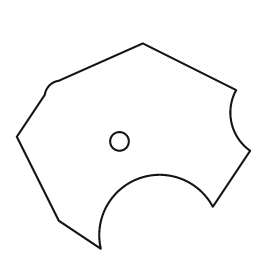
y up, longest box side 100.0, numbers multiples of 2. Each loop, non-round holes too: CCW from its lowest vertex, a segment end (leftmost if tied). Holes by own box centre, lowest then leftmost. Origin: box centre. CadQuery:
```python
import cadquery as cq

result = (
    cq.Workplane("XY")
    .moveTo(-14.0, -44.0)
    .threePointArc((2.0, -14.0), (34.0, -26.0))
    .lineTo(50.0, -2.0)
    .threePointArc((42.0, 10.0), (44.0, 24.0))
    .lineTo(4.0, 44.0)
    .lineTo(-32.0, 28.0)
    .threePointArc((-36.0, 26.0), (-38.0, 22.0))
    .lineTo(-50.0, 4.0)
    .lineTo(-32.0, -32.0)
    .close()
    .moveTo(-6.0, 2.0)
    .circle(4.0)
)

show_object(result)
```